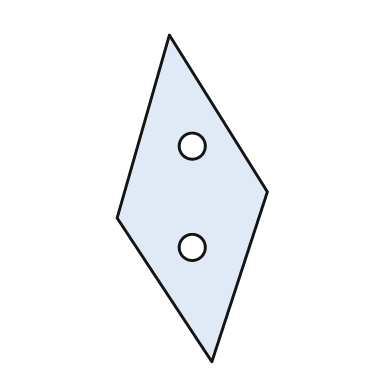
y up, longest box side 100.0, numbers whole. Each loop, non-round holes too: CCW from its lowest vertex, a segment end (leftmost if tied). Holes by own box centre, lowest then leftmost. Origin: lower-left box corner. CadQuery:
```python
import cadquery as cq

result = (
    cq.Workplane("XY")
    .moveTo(29.0, 0.0)
    .lineTo(46.0, 52.0)
    .lineTo(16.0, 100.0)
    .lineTo(0.0, 44.0)
    .close()
    .moveTo(23.0, 35.0)
    .circle(4.0)
    .moveTo(23.0, 66.0)
    .circle(4.0)
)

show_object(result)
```